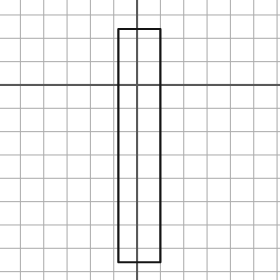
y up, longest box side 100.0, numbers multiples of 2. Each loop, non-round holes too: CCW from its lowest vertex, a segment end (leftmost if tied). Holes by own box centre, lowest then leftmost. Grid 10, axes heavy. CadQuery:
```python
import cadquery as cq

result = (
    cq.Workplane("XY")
    .moveTo(-8.0, -76.0)
    .lineTo(10.0, -76.0)
    .lineTo(10.0, 24.0)
    .lineTo(-8.0, 24.0)
    .close()
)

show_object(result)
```